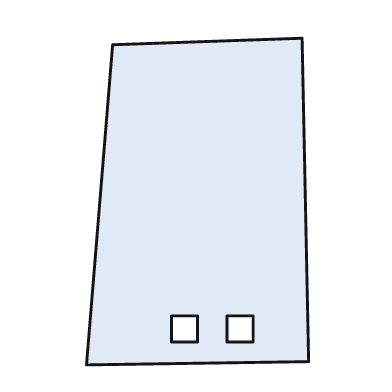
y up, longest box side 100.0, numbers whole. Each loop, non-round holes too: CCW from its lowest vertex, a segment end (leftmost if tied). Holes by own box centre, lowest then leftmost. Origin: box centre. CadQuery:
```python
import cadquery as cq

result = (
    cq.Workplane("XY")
    .moveTo(-34.0, -50.0)
    .lineTo(34.0, -49.0)
    .lineTo(32.0, 50.0)
    .lineTo(-26.0, 48.0)
    .close()
    .moveTo(-8.0, -43.0)
    .lineTo(0.0, -43.0)
    .lineTo(0.0, -35.0)
    .lineTo(-8.0, -35.0)
    .close()
    .moveTo(9.0, -43.0)
    .lineTo(17.0, -43.0)
    .lineTo(17.0, -35.0)
    .lineTo(9.0, -35.0)
    .close()
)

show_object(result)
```